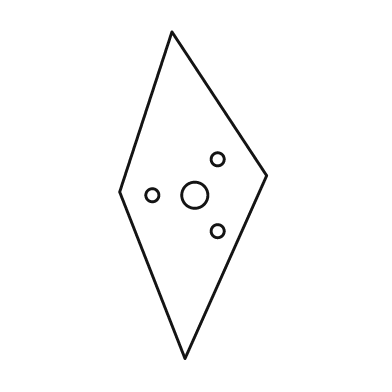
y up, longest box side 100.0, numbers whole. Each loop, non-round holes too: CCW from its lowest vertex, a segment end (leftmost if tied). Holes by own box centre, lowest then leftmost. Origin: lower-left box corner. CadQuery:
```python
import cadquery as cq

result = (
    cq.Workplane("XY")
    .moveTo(20.0, 0.0)
    .lineTo(45.0, 56.0)
    .lineTo(16.0, 100.0)
    .lineTo(0.0, 51.0)
    .close()
    .moveTo(30.0, 39.0)
    .circle(2.0)
    .moveTo(10.0, 50.0)
    .circle(2.0)
    .moveTo(23.0, 50.0)
    .circle(4.0)
    .moveTo(30.0, 61.0)
    .circle(2.0)
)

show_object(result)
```